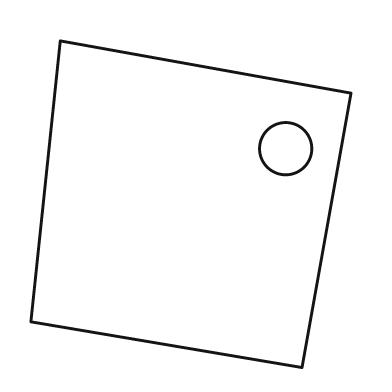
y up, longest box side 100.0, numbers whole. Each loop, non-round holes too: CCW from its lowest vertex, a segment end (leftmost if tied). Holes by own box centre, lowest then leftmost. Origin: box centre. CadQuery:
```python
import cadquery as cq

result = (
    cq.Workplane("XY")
    .moveTo(34.0, -50.0)
    .lineTo(49.0, 34.0)
    .lineTo(-40.0, 50.0)
    .lineTo(-49.0, -36.0)
    .close()
    .moveTo(29.0, 17.0)
    .circle(8.0)
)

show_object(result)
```